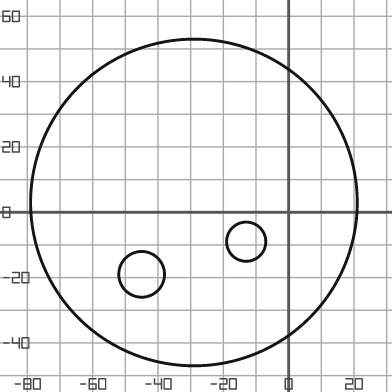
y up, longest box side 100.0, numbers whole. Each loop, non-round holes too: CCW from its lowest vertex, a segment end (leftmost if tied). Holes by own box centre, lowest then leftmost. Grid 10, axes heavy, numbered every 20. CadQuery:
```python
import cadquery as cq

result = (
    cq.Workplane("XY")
    .moveTo(-29.0, 3.0)
    .circle(50.0)
    .moveTo(-45.0, -19.0)
    .circle(7.0)
    .moveTo(-13.0, -9.0)
    .circle(6.0)
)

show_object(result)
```